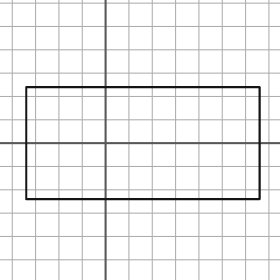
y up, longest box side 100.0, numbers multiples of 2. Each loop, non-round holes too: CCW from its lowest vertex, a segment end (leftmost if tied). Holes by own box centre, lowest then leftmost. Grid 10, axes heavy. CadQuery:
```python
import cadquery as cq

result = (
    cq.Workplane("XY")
    .moveTo(-34.0, -24.0)
    .lineTo(66.0, -24.0)
    .lineTo(66.0, 24.0)
    .lineTo(-34.0, 24.0)
    .close()
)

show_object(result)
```